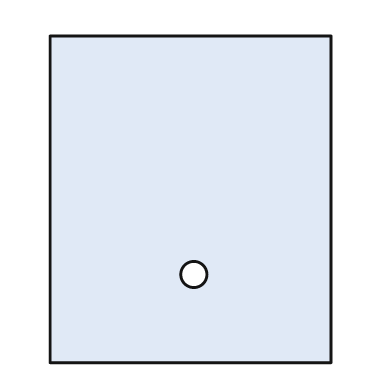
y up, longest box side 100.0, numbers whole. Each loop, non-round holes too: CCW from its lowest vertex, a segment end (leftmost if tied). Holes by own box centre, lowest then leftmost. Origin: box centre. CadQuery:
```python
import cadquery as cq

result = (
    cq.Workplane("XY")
    .moveTo(-43.0, -50.0)
    .lineTo(43.0, -50.0)
    .lineTo(43.0, 50.0)
    .lineTo(-43.0, 50.0)
    .close()
    .moveTo(1.0, -23.0)
    .circle(4.0)
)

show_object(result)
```